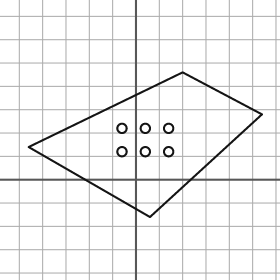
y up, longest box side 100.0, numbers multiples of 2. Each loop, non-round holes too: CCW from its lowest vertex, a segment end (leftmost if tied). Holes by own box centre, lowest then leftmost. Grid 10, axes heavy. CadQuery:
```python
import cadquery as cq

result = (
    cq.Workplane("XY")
    .moveTo(6.0, -16.0)
    .lineTo(54.0, 28.0)
    .lineTo(20.0, 46.0)
    .lineTo(-46.0, 14.0)
    .close()
    .moveTo(-6.0, 12.0)
    .circle(2.0)
    .moveTo(4.0, 12.0)
    .circle(2.0)
    .moveTo(14.0, 12.0)
    .circle(2.0)
    .moveTo(-6.0, 22.0)
    .circle(2.0)
    .moveTo(4.0, 22.0)
    .circle(2.0)
    .moveTo(14.0, 22.0)
    .circle(2.0)
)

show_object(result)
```